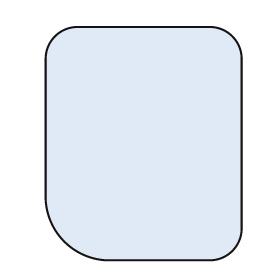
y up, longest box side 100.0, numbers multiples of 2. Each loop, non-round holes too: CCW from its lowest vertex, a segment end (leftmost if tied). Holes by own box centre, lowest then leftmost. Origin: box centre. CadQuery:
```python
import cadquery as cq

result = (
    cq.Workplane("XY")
    .moveTo(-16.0, -50.0)
    .lineTo(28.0, -50.0)
    .threePointArc((38.0, -46.0), (42.0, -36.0))
    .lineTo(42.0, 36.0)
    .threePointArc((38.0, 46.0), (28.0, 50.0))
    .lineTo(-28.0, 50.0)
    .threePointArc((-38.0, 46.0), (-42.0, 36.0))
    .lineTo(-42.0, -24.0)
    .threePointArc((-34.0, -42.0), (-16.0, -50.0))
    .close()
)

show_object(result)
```